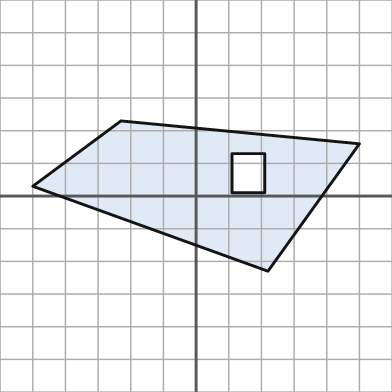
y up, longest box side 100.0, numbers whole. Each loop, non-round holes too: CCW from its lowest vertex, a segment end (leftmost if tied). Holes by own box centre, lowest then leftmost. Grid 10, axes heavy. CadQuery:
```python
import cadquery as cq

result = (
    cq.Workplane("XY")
    .moveTo(22.0, -23.0)
    .lineTo(50.0, 16.0)
    .lineTo(-23.0, 23.0)
    .lineTo(-50.0, 3.0)
    .close()
    .moveTo(11.0, 1.0)
    .lineTo(21.0, 1.0)
    .lineTo(21.0, 13.0)
    .lineTo(11.0, 13.0)
    .close()
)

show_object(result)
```